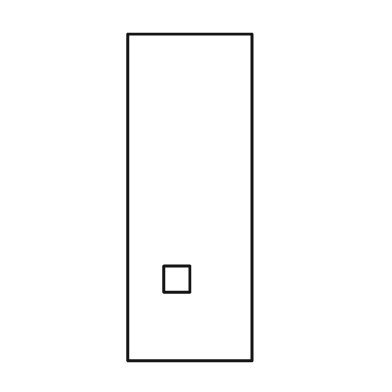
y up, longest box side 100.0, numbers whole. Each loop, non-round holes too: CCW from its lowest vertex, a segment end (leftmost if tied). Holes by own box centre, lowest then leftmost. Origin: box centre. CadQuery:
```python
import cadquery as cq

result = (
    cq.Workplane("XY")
    .moveTo(-19.0, -50.0)
    .lineTo(19.0, -50.0)
    .lineTo(19.0, 50.0)
    .lineTo(-19.0, 50.0)
    .close()
    .moveTo(-8.0, -29.0)
    .lineTo(0.0, -29.0)
    .lineTo(0.0, -21.0)
    .lineTo(-8.0, -21.0)
    .close()
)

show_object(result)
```